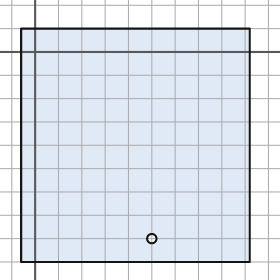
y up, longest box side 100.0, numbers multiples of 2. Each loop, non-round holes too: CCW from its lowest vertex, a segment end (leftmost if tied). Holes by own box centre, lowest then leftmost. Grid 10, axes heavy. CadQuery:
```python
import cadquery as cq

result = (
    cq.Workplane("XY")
    .moveTo(-6.0, -90.0)
    .lineTo(92.0, -90.0)
    .lineTo(92.0, 10.0)
    .lineTo(-6.0, 10.0)
    .close()
    .moveTo(50.0, -80.0)
    .circle(2.0)
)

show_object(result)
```